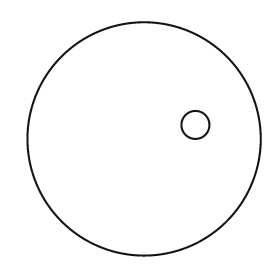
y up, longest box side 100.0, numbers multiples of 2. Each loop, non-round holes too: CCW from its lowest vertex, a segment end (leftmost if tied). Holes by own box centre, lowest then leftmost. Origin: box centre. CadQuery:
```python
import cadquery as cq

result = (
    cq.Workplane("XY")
    .moveTo(0.0, 0.0)
    .circle(50.0)
    .moveTo(22.0, 6.0)
    .circle(6.0)
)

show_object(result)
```